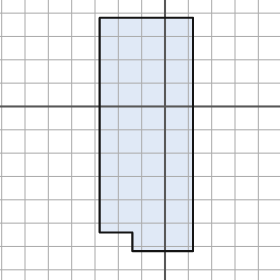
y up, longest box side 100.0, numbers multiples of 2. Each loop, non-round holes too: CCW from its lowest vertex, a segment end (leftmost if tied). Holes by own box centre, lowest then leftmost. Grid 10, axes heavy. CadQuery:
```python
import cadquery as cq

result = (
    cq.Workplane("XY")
    .moveTo(-14.0, -62.0)
    .lineTo(12.0, -62.0)
    .lineTo(12.0, 38.0)
    .lineTo(-28.0, 38.0)
    .lineTo(-28.0, -54.0)
    .lineTo(-14.0, -54.0)
    .close()
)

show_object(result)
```